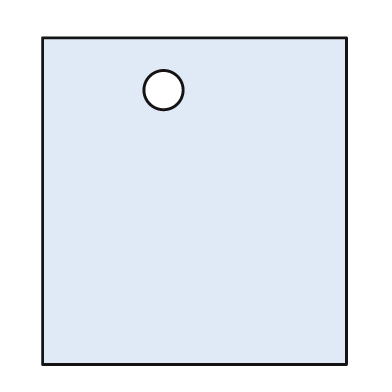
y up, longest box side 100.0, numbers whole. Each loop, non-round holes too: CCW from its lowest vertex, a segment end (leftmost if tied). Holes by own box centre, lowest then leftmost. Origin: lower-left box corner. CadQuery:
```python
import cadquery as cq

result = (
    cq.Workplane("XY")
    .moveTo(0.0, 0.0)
    .lineTo(93.0, 0.0)
    .lineTo(93.0, 100.0)
    .lineTo(0.0, 100.0)
    .close()
    .moveTo(37.0, 84.0)
    .circle(6.0)
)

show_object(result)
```